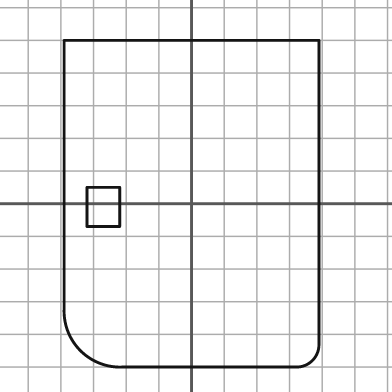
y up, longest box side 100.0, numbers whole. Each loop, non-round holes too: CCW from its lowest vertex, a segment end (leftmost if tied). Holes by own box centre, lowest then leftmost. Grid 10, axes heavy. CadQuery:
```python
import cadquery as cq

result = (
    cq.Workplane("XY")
    .moveTo(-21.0, -50.0)
    .lineTo(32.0, -50.0)
    .threePointArc((37.0, -48.0), (39.0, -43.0))
    .lineTo(39.0, 50.0)
    .lineTo(-39.0, 50.0)
    .lineTo(-39.0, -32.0)
    .threePointArc((-34.0, -45.0), (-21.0, -50.0))
    .close()
    .moveTo(-32.0, -7.0)
    .lineTo(-22.0, -7.0)
    .lineTo(-22.0, 5.0)
    .lineTo(-32.0, 5.0)
    .close()
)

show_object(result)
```